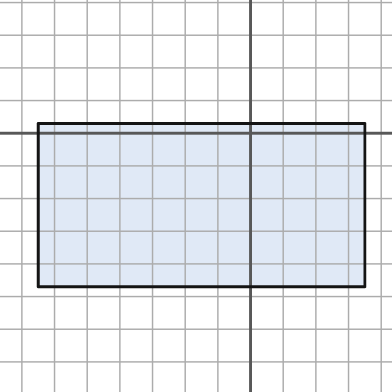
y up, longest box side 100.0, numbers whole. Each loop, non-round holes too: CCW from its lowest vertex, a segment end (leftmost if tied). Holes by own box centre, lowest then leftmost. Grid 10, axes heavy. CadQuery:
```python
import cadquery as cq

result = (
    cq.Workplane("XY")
    .moveTo(-65.0, -47.0)
    .lineTo(35.0, -47.0)
    .lineTo(35.0, 3.0)
    .lineTo(-65.0, 3.0)
    .close()
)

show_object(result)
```